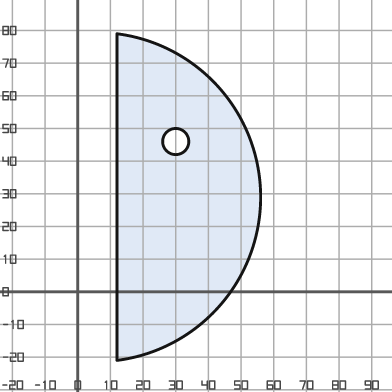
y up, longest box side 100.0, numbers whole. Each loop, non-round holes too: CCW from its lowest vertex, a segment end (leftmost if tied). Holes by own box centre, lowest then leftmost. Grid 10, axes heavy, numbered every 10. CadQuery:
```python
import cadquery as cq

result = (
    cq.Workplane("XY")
    .moveTo(12.0, -21.0)
    .threePointArc((56.0, 29.0), (12.0, 79.0))
    .close()
    .moveTo(30.0, 46.0)
    .circle(4.0)
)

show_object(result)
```